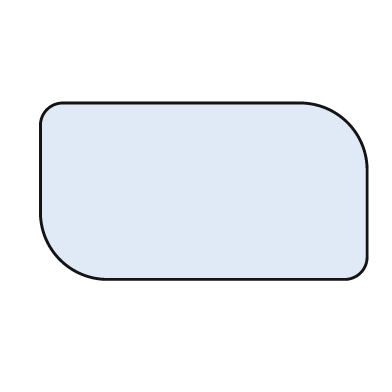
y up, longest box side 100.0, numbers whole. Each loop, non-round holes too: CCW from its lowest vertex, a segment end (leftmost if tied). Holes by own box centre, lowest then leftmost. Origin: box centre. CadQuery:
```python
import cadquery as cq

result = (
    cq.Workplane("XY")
    .moveTo(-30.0, -27.0)
    .lineTo(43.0, -27.0)
    .threePointArc((48.0, -25.0), (50.0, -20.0))
    .lineTo(50.0, 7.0)
    .threePointArc((44.0, 21.0), (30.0, 27.0))
    .lineTo(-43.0, 27.0)
    .threePointArc((-48.0, 25.0), (-50.0, 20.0))
    .lineTo(-50.0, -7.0)
    .threePointArc((-44.0, -21.0), (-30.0, -27.0))
    .close()
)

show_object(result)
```